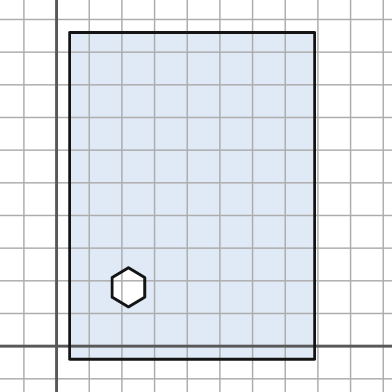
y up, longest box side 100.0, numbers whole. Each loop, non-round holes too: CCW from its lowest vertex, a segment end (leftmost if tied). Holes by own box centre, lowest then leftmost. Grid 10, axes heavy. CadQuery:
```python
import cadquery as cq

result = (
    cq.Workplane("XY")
    .moveTo(4.0, -4.0)
    .lineTo(79.0, -4.0)
    .lineTo(79.0, 96.0)
    .lineTo(4.0, 96.0)
    .close()
    .moveTo(22.0, 12.0)
    .lineTo(27.0, 15.0)
    .lineTo(27.0, 21.0)
    .lineTo(22.0, 24.0)
    .lineTo(17.0, 21.0)
    .lineTo(17.0, 15.0)
    .close()
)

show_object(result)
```